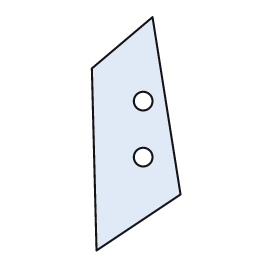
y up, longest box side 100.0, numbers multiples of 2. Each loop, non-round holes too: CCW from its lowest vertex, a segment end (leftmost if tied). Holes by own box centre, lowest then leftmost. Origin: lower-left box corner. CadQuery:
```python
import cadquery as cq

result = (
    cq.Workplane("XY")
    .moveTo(2.0, 0.0)
    .lineTo(38.0, 24.0)
    .lineTo(26.0, 100.0)
    .lineTo(0.0, 78.0)
    .close()
    .moveTo(22.0, 40.0)
    .circle(4.0)
    .moveTo(22.0, 64.0)
    .circle(4.0)
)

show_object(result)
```